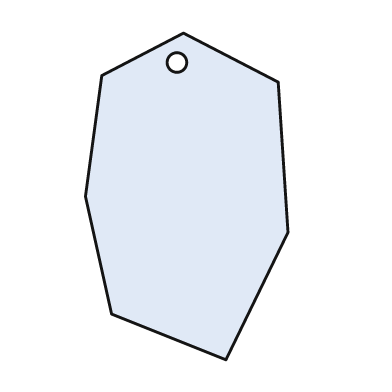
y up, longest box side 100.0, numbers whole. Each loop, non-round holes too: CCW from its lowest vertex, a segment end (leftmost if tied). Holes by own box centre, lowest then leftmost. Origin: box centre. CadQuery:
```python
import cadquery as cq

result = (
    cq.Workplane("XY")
    .moveTo(12.0, -50.0)
    .lineTo(31.0, -11.0)
    .lineTo(28.0, 35.0)
    .lineTo(-1.0, 50.0)
    .lineTo(-26.0, 37.0)
    .lineTo(-31.0, 0.0)
    .lineTo(-23.0, -36.0)
    .close()
    .moveTo(-3.0, 41.0)
    .circle(3.0)
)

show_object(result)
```